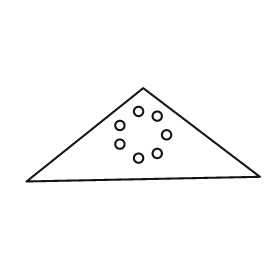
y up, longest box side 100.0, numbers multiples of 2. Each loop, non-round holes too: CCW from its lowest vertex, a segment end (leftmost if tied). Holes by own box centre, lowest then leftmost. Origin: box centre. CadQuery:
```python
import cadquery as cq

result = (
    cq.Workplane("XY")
    .moveTo(-50.0, -20.0)
    .lineTo(50.0, -18.0)
    .lineTo(0.0, 20.0)
    .close()
    .moveTo(-2.0, -10.0)
    .circle(2.0)
    .moveTo(6.0, -8.0)
    .circle(2.0)
    .moveTo(-10.0, -4.0)
    .circle(2.0)
    .moveTo(10.0, 0.0)
    .circle(2.0)
    .moveTo(-10.0, 4.0)
    .circle(2.0)
    .moveTo(6.0, 8.0)
    .circle(2.0)
    .moveTo(-2.0, 10.0)
    .circle(2.0)
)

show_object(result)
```